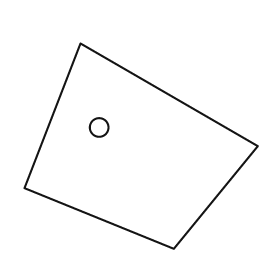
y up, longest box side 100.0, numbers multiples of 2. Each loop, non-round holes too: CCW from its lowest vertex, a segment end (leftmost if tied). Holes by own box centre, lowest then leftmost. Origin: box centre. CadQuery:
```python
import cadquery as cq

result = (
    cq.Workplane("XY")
    .moveTo(14.0, -44.0)
    .lineTo(50.0, 0.0)
    .lineTo(-26.0, 44.0)
    .lineTo(-50.0, -18.0)
    .close()
    .moveTo(-18.0, 8.0)
    .circle(4.0)
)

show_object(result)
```